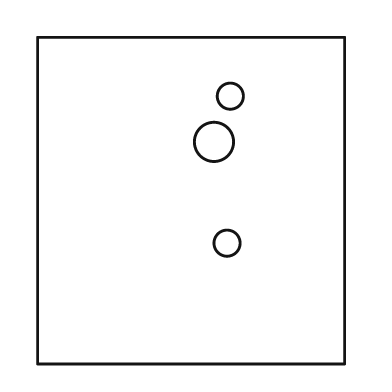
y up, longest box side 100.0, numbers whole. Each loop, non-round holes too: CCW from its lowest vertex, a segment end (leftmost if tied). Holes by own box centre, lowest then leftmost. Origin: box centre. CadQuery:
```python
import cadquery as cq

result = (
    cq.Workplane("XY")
    .moveTo(-47.0, -50.0)
    .lineTo(47.0, -50.0)
    .lineTo(47.0, 50.0)
    .lineTo(-47.0, 50.0)
    .close()
    .moveTo(11.0, -13.0)
    .circle(4.0)
    .moveTo(7.0, 18.0)
    .circle(6.0)
    .moveTo(12.0, 32.0)
    .circle(4.0)
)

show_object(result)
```